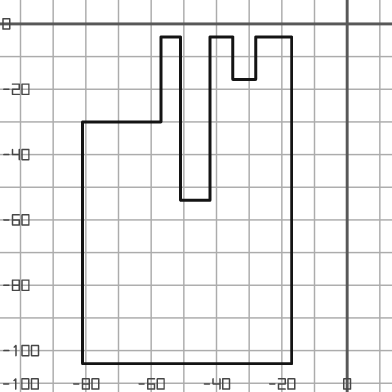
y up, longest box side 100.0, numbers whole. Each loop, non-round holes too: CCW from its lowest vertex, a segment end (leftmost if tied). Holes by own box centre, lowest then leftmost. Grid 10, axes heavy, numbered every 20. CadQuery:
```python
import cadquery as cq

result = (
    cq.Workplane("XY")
    .moveTo(-81.0, -104.0)
    .lineTo(-17.0, -104.0)
    .lineTo(-17.0, -4.0)
    .lineTo(-28.0, -4.0)
    .lineTo(-28.0, -17.0)
    .lineTo(-35.0, -17.0)
    .lineTo(-35.0, -4.0)
    .lineTo(-42.0, -4.0)
    .lineTo(-42.0, -54.0)
    .lineTo(-51.0, -54.0)
    .lineTo(-51.0, -4.0)
    .lineTo(-57.0, -4.0)
    .lineTo(-57.0, -30.0)
    .lineTo(-81.0, -30.0)
    .close()
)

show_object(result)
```